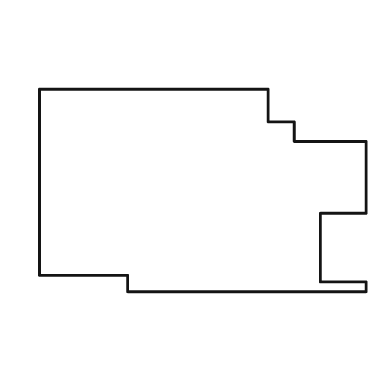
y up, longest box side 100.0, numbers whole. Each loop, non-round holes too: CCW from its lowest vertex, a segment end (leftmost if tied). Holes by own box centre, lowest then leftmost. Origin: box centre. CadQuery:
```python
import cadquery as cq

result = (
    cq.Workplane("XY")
    .moveTo(-23.0, -31.0)
    .lineTo(50.0, -31.0)
    .lineTo(50.0, -28.0)
    .lineTo(36.0, -28.0)
    .lineTo(36.0, -7.0)
    .lineTo(50.0, -7.0)
    .lineTo(50.0, 15.0)
    .lineTo(28.0, 15.0)
    .lineTo(28.0, 21.0)
    .lineTo(20.0, 21.0)
    .lineTo(20.0, 31.0)
    .lineTo(-50.0, 31.0)
    .lineTo(-50.0, -26.0)
    .lineTo(-23.0, -26.0)
    .close()
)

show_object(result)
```